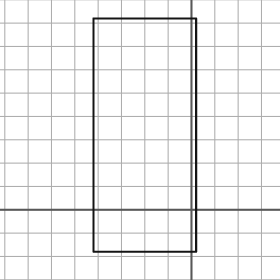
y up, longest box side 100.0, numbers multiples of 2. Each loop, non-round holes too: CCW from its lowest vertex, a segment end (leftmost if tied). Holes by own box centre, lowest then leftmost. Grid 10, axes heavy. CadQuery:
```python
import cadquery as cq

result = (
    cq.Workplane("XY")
    .moveTo(-42.0, -18.0)
    .lineTo(2.0, -18.0)
    .lineTo(2.0, 82.0)
    .lineTo(-42.0, 82.0)
    .close()
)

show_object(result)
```